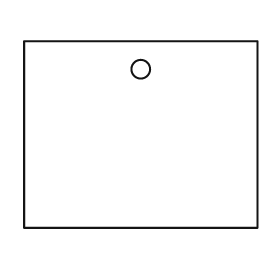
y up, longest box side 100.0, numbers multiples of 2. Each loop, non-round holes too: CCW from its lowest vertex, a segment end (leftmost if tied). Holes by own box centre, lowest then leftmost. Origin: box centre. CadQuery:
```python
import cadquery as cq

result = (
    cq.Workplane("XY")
    .moveTo(-50.0, -40.0)
    .lineTo(50.0, -40.0)
    .lineTo(50.0, 40.0)
    .lineTo(-50.0, 40.0)
    .close()
    .moveTo(0.0, 28.0)
    .circle(4.0)
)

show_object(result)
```